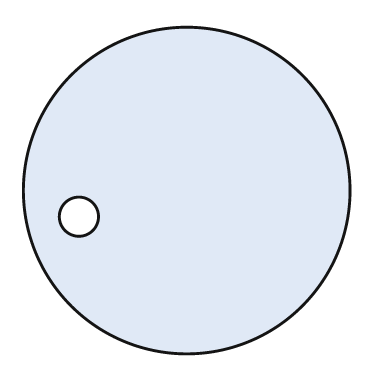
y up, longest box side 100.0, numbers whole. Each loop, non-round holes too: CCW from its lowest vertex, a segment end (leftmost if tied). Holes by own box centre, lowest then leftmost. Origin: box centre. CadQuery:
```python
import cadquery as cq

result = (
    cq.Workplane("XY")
    .moveTo(0.0, 0.0)
    .circle(50.0)
    .moveTo(-33.0, -8.0)
    .circle(6.0)
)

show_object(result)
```